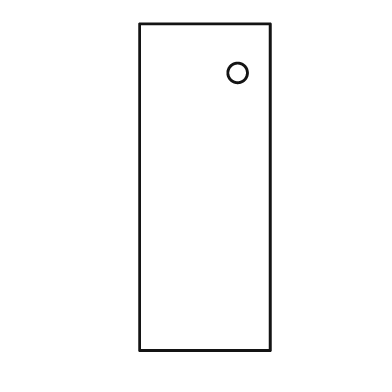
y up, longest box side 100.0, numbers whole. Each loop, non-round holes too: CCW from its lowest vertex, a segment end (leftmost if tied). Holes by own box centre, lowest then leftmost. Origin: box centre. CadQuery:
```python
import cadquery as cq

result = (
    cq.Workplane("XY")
    .moveTo(-20.0, -50.0)
    .lineTo(20.0, -50.0)
    .lineTo(20.0, 50.0)
    .lineTo(-20.0, 50.0)
    .close()
    .moveTo(10.0, 35.0)
    .circle(3.0)
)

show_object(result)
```